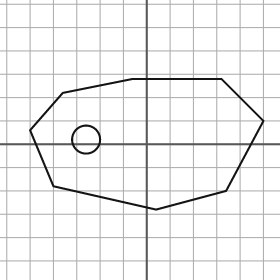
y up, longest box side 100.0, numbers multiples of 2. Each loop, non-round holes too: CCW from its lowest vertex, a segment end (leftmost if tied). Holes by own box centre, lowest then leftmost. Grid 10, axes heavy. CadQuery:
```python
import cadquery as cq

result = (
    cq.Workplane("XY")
    .moveTo(4.0, -28.0)
    .lineTo(34.0, -20.0)
    .lineTo(50.0, 10.0)
    .lineTo(32.0, 28.0)
    .lineTo(-6.0, 28.0)
    .lineTo(-36.0, 22.0)
    .lineTo(-50.0, 6.0)
    .lineTo(-40.0, -18.0)
    .close()
    .moveTo(-26.0, 2.0)
    .circle(6.0)
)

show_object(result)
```